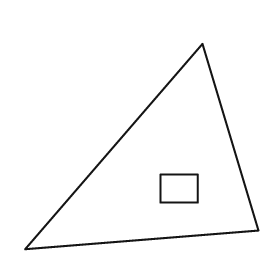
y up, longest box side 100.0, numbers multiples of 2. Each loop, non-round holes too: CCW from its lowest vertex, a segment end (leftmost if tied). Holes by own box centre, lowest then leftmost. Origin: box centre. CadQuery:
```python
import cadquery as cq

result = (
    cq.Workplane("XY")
    .moveTo(-50.0, -44.0)
    .lineTo(50.0, -36.0)
    .lineTo(26.0, 44.0)
    .close()
    .moveTo(8.0, -24.0)
    .lineTo(24.0, -24.0)
    .lineTo(24.0, -12.0)
    .lineTo(8.0, -12.0)
    .close()
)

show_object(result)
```